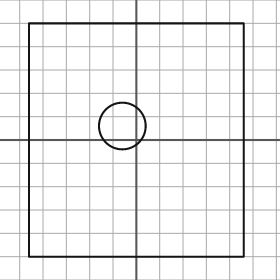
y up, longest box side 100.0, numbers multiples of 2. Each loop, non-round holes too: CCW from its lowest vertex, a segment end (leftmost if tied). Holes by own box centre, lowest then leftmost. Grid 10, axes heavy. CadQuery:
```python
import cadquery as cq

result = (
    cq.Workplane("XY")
    .moveTo(-46.0, -50.0)
    .lineTo(46.0, -50.0)
    .lineTo(46.0, 50.0)
    .lineTo(-46.0, 50.0)
    .close()
    .moveTo(-6.0, 6.0)
    .circle(10.0)
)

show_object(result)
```